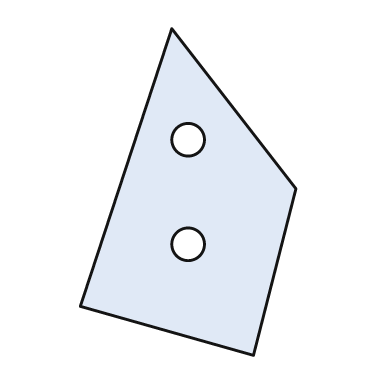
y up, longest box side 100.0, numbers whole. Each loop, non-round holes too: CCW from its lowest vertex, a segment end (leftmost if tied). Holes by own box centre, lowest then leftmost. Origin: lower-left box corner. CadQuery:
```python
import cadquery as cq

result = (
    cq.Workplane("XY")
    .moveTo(53.0, 0.0)
    .lineTo(66.0, 51.0)
    .lineTo(28.0, 100.0)
    .lineTo(0.0, 15.0)
    .close()
    .moveTo(33.0, 34.0)
    .circle(5.0)
    .moveTo(33.0, 66.0)
    .circle(5.0)
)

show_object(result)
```